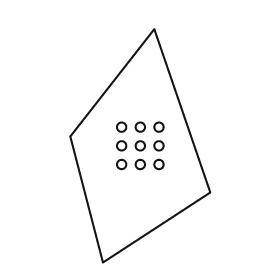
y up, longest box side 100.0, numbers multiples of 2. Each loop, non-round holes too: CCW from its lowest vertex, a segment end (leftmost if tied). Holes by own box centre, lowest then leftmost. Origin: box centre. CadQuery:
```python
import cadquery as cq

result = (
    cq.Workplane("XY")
    .moveTo(-16.0, -50.0)
    .lineTo(30.0, -20.0)
    .lineTo(6.0, 50.0)
    .lineTo(-30.0, 4.0)
    .close()
    .moveTo(-8.0, -8.0)
    .circle(2.0)
    .moveTo(0.0, -8.0)
    .circle(2.0)
    .moveTo(8.0, -8.0)
    .circle(2.0)
    .moveTo(-8.0, 0.0)
    .circle(2.0)
    .moveTo(0.0, 0.0)
    .circle(2.0)
    .moveTo(8.0, 0.0)
    .circle(2.0)
    .moveTo(-8.0, 8.0)
    .circle(2.0)
    .moveTo(0.0, 8.0)
    .circle(2.0)
    .moveTo(8.0, 8.0)
    .circle(2.0)
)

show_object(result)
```